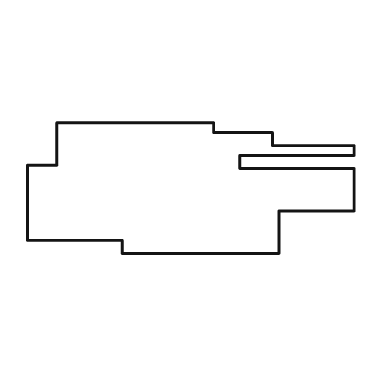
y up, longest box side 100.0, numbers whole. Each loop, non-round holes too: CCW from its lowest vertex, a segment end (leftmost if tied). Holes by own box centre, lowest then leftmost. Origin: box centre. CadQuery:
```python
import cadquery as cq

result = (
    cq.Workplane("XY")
    .moveTo(-21.0, -20.0)
    .lineTo(27.0, -20.0)
    .lineTo(27.0, -7.0)
    .lineTo(50.0, -7.0)
    .lineTo(50.0, 6.0)
    .lineTo(15.0, 6.0)
    .lineTo(15.0, 10.0)
    .lineTo(50.0, 10.0)
    .lineTo(50.0, 13.0)
    .lineTo(25.0, 13.0)
    .lineTo(25.0, 17.0)
    .lineTo(7.0, 17.0)
    .lineTo(7.0, 20.0)
    .lineTo(-41.0, 20.0)
    .lineTo(-41.0, 7.0)
    .lineTo(-50.0, 7.0)
    .lineTo(-50.0, -16.0)
    .lineTo(-21.0, -16.0)
    .close()
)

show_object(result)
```